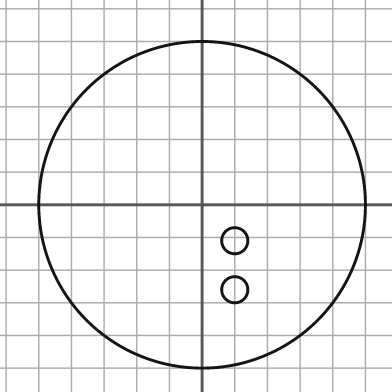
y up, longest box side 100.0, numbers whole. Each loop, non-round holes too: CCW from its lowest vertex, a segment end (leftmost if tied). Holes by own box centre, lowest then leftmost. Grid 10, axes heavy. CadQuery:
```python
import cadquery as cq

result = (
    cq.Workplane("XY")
    .moveTo(0.0, 0.0)
    .circle(50.0)
    .moveTo(10.0, -26.0)
    .circle(4.0)
    .moveTo(10.0, -11.0)
    .circle(4.0)
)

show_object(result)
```